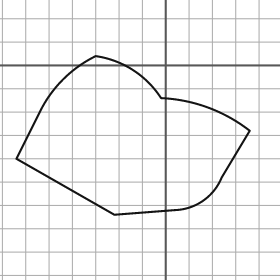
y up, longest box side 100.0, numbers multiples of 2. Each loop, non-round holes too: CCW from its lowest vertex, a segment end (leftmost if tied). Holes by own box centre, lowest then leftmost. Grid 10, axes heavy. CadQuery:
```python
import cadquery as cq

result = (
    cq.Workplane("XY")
    .moveTo(-22.0, -64.0)
    .lineTo(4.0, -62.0)
    .threePointArc((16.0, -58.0), (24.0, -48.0))
    .lineTo(36.0, -28.0)
    .threePointArc((18.0, -18.0), (-2.0, -14.0))
    .threePointArc((-14.0, -2.0), (-30.0, 4.0))
    .threePointArc((-44.0, -6.0), (-54.0, -20.0))
    .lineTo(-64.0, -40.0)
    .close()
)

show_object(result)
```